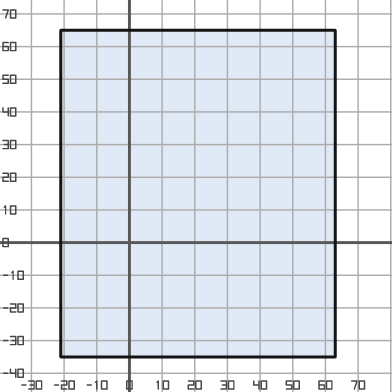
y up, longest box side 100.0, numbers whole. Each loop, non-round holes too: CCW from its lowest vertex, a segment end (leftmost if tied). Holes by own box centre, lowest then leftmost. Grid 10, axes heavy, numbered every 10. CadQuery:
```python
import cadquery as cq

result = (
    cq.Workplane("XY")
    .moveTo(-21.0, -35.0)
    .lineTo(63.0, -35.0)
    .lineTo(63.0, 65.0)
    .lineTo(-21.0, 65.0)
    .close()
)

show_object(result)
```